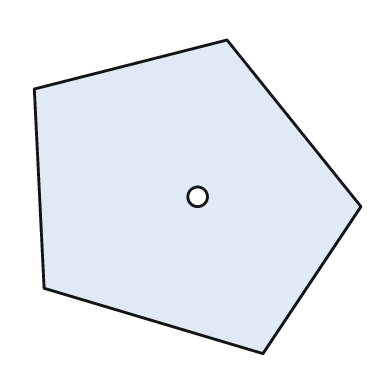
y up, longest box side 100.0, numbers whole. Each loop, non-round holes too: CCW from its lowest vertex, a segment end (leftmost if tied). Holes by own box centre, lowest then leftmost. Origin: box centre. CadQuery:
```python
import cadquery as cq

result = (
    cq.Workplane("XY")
    .moveTo(20.0, -48.0)
    .lineTo(50.0, -3.0)
    .lineTo(9.0, 48.0)
    .lineTo(-50.0, 33.0)
    .lineTo(-47.0, -28.0)
    .close()
    .moveTo(0.0, 0.0)
    .circle(3.0)
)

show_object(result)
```